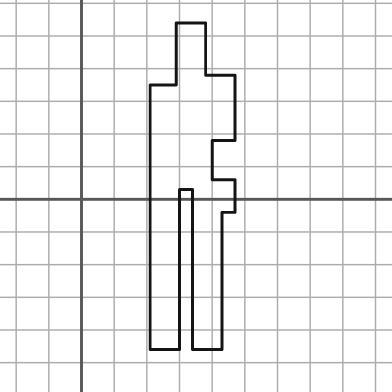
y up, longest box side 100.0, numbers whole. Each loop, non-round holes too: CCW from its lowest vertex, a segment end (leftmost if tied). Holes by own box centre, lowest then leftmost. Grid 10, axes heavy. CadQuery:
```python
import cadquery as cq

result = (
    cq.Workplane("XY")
    .moveTo(21.0, -46.0)
    .lineTo(30.0, -46.0)
    .lineTo(30.0, 3.0)
    .lineTo(34.0, 3.0)
    .lineTo(34.0, -46.0)
    .lineTo(43.0, -46.0)
    .lineTo(43.0, -4.0)
    .lineTo(47.0, -4.0)
    .lineTo(47.0, 6.0)
    .lineTo(40.0, 6.0)
    .lineTo(40.0, 18.0)
    .lineTo(47.0, 18.0)
    .lineTo(47.0, 38.0)
    .lineTo(38.0, 38.0)
    .lineTo(38.0, 54.0)
    .lineTo(29.0, 54.0)
    .lineTo(29.0, 35.0)
    .lineTo(21.0, 35.0)
    .close()
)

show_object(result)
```